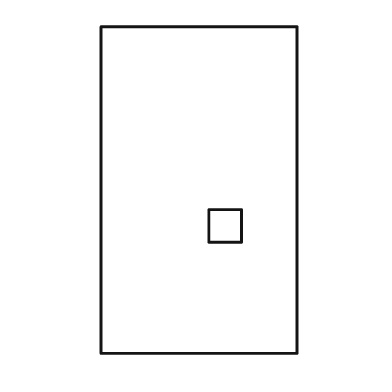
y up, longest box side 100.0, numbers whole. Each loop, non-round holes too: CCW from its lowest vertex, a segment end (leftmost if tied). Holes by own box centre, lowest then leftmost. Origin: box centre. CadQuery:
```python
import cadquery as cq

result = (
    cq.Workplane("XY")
    .moveTo(-30.0, -50.0)
    .lineTo(30.0, -50.0)
    .lineTo(30.0, 50.0)
    .lineTo(-30.0, 50.0)
    .close()
    .moveTo(3.0, -16.0)
    .lineTo(13.0, -16.0)
    .lineTo(13.0, -6.0)
    .lineTo(3.0, -6.0)
    .close()
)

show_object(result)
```